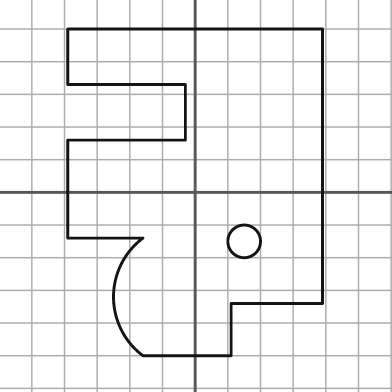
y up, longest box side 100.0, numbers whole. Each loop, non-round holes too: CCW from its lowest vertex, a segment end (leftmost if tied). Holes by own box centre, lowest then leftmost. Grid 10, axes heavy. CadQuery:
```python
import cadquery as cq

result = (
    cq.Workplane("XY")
    .moveTo(-16.0, -50.0)
    .lineTo(11.0, -50.0)
    .lineTo(11.0, -34.0)
    .lineTo(39.0, -34.0)
    .lineTo(39.0, 50.0)
    .lineTo(-39.0, 50.0)
    .lineTo(-39.0, 33.0)
    .lineTo(-3.0, 33.0)
    .lineTo(-3.0, 16.0)
    .lineTo(-39.0, 16.0)
    .lineTo(-39.0, -14.0)
    .lineTo(-16.0, -14.0)
    .threePointArc((-25.0, -32.0), (-16.0, -50.0))
    .close()
    .moveTo(15.0, -15.0)
    .circle(5.0)
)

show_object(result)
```